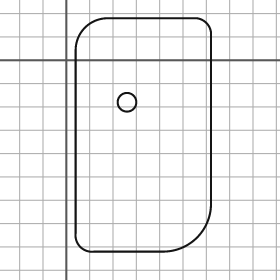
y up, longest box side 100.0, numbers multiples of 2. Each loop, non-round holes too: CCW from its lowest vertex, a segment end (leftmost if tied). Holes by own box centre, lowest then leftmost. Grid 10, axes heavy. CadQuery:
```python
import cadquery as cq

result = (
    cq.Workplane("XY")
    .moveTo(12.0, -82.0)
    .lineTo(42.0, -82.0)
    .threePointArc((56.0, -76.0), (62.0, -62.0))
    .lineTo(62.0, 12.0)
    .threePointArc((60.0, 16.0), (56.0, 18.0))
    .lineTo(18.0, 18.0)
    .threePointArc((8.0, 14.0), (4.0, 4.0))
    .lineTo(4.0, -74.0)
    .threePointArc((6.0, -80.0), (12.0, -82.0))
    .close()
    .moveTo(26.0, -18.0)
    .circle(4.0)
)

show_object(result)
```